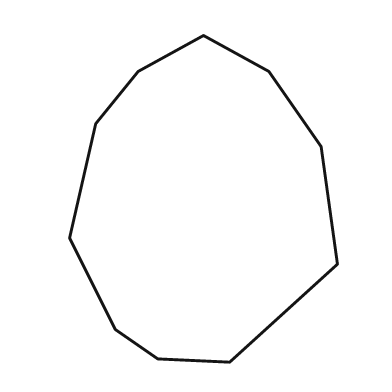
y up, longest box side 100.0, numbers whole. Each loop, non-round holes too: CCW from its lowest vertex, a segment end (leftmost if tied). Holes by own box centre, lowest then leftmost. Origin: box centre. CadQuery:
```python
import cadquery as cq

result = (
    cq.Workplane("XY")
    .moveTo(8.0, -50.0)
    .lineTo(41.0, -20.0)
    .lineTo(36.0, 16.0)
    .lineTo(20.0, 39.0)
    .lineTo(0.0, 50.0)
    .lineTo(-20.0, 39.0)
    .lineTo(-33.0, 23.0)
    .lineTo(-41.0, -12.0)
    .lineTo(-27.0, -40.0)
    .lineTo(-14.0, -49.0)
    .close()
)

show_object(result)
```